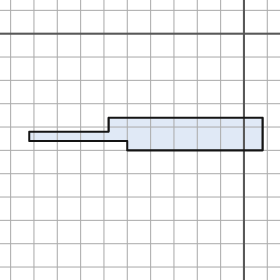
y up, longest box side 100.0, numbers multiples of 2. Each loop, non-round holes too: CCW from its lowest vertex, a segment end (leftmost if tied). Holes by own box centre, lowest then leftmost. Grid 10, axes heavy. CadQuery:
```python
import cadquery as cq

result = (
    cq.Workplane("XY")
    .moveTo(-50.0, -50.0)
    .lineTo(8.0, -50.0)
    .lineTo(8.0, -36.0)
    .lineTo(-58.0, -36.0)
    .lineTo(-58.0, -42.0)
    .lineTo(-92.0, -42.0)
    .lineTo(-92.0, -46.0)
    .lineTo(-50.0, -46.0)
    .close()
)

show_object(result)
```